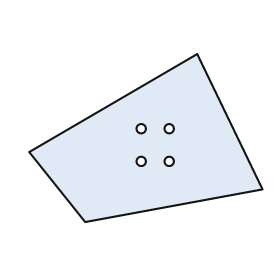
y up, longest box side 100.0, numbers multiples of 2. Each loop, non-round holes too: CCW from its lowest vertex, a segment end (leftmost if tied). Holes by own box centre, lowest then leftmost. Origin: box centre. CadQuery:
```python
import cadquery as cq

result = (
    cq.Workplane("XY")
    .moveTo(-26.0, -36.0)
    .lineTo(50.0, -22.0)
    .lineTo(22.0, 36.0)
    .lineTo(-50.0, -6.0)
    .close()
    .moveTo(-2.0, -10.0)
    .circle(2.0)
    .moveTo(10.0, -10.0)
    .circle(2.0)
    .moveTo(-2.0, 4.0)
    .circle(2.0)
    .moveTo(10.0, 4.0)
    .circle(2.0)
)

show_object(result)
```